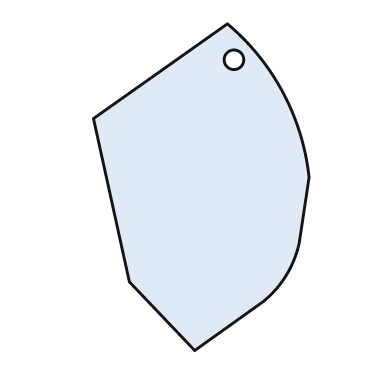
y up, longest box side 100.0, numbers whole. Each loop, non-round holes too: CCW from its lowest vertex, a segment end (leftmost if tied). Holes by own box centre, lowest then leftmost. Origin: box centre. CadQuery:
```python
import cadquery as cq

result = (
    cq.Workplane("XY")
    .moveTo(-2.0, -50.0)
    .lineTo(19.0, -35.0)
    .threePointArc((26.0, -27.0), (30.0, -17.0))
    .lineTo(33.0, 3.0)
    .threePointArc((25.0, 29.0), (8.0, 50.0))
    .lineTo(-33.0, 21.0)
    .lineTo(-22.0, -29.0)
    .close()
    .moveTo(10.0, 39.0)
    .circle(3.0)
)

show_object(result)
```